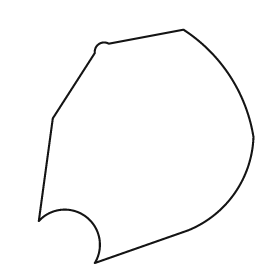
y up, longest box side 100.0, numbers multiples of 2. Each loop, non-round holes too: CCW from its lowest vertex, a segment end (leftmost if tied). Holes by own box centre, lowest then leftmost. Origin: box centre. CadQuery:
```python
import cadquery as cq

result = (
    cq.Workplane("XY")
    .moveTo(-22.0, -50.0)
    .lineTo(18.0, -36.0)
    .threePointArc((38.0, -20.0), (46.0, 4.0))
    .threePointArc((36.0, 30.0), (16.0, 50.0))
    .lineTo(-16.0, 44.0)
    .threePointArc((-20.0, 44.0), (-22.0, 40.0))
    .lineTo(-40.0, 12.0)
    .lineTo(-46.0, -32.0)
    .threePointArc((-26.0, -30.0), (-22.0, -50.0))
    .close()
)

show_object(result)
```